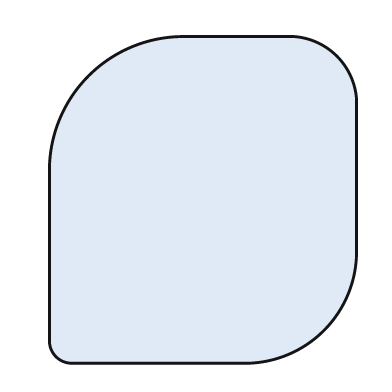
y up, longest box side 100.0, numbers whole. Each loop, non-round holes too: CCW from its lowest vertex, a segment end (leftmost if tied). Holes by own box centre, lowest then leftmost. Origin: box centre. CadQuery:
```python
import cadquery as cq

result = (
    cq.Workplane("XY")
    .moveTo(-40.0, -50.0)
    .lineTo(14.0, -50.0)
    .threePointArc((37.0, -40.0), (47.0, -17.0))
    .lineTo(47.0, 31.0)
    .threePointArc((41.0, 44.0), (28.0, 50.0))
    .lineTo(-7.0, 50.0)
    .threePointArc((-35.0, 38.0), (-47.0, 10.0))
    .lineTo(-47.0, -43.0)
    .threePointArc((-45.0, -48.0), (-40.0, -50.0))
    .close()
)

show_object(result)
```